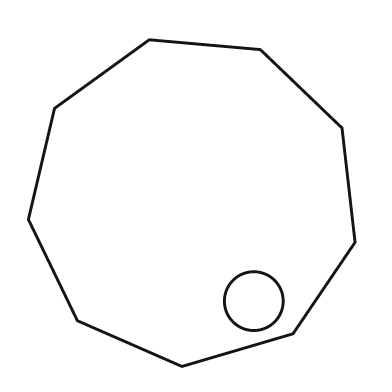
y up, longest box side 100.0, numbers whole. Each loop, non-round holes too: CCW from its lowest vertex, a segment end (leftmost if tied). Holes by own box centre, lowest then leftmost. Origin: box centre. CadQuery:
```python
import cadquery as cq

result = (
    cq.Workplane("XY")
    .moveTo(-3.0, -50.0)
    .lineTo(31.0, -40.0)
    .lineTo(50.0, -12.0)
    .lineTo(46.0, 23.0)
    .lineTo(21.0, 47.0)
    .lineTo(-13.0, 50.0)
    .lineTo(-42.0, 29.0)
    .lineTo(-50.0, -5.0)
    .lineTo(-35.0, -36.0)
    .close()
    .moveTo(19.0, -30.0)
    .circle(9.0)
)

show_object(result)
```